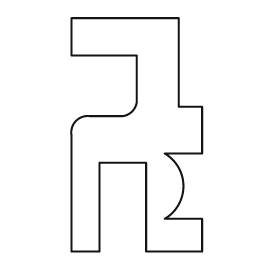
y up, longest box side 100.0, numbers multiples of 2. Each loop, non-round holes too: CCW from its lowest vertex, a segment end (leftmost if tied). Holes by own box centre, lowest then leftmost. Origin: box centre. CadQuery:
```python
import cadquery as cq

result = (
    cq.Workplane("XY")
    .moveTo(-28.0, -50.0)
    .lineTo(-16.0, -50.0)
    .lineTo(-16.0, -12.0)
    .lineTo(4.0, -12.0)
    .lineTo(4.0, -50.0)
    .lineTo(28.0, -50.0)
    .lineTo(28.0, -36.0)
    .lineTo(12.0, -36.0)
    .threePointArc((20.0, -22.0), (12.0, -8.0))
    .lineTo(28.0, -8.0)
    .lineTo(28.0, 12.0)
    .lineTo(18.0, 12.0)
    .lineTo(18.0, 50.0)
    .lineTo(-28.0, 50.0)
    .lineTo(-28.0, 34.0)
    .lineTo(0.0, 34.0)
    .lineTo(0.0, 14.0)
    .threePointArc((-2.0, 10.0), (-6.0, 8.0))
    .lineTo(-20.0, 8.0)
    .threePointArc((-26.0, 6.0), (-28.0, 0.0))
    .close()
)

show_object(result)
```